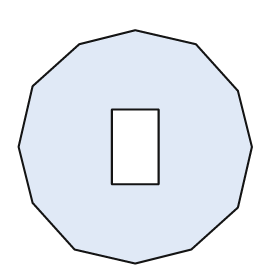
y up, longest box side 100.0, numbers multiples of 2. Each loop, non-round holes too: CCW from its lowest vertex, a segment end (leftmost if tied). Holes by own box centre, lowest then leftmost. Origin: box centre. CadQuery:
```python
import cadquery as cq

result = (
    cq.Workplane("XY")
    .moveTo(0.0, -50.0)
    .lineTo(24.0, -44.0)
    .lineTo(44.0, -26.0)
    .lineTo(50.0, 0.0)
    .lineTo(44.0, 24.0)
    .lineTo(26.0, 44.0)
    .lineTo(0.0, 50.0)
    .lineTo(-24.0, 44.0)
    .lineTo(-44.0, 26.0)
    .lineTo(-50.0, 0.0)
    .lineTo(-44.0, -24.0)
    .lineTo(-26.0, -44.0)
    .close()
    .moveTo(-10.0, -16.0)
    .lineTo(10.0, -16.0)
    .lineTo(10.0, 16.0)
    .lineTo(-10.0, 16.0)
    .close()
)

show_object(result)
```